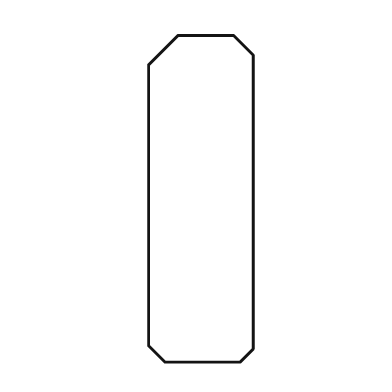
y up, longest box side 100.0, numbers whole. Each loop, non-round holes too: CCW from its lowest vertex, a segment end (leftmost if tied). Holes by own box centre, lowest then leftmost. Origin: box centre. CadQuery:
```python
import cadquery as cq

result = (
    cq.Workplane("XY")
    .moveTo(-11.0, -50.0)
    .lineTo(12.0, -50.0)
    .lineTo(16.0, -46.0)
    .lineTo(16.0, 44.0)
    .lineTo(10.0, 50.0)
    .lineTo(-7.0, 50.0)
    .lineTo(-16.0, 41.0)
    .lineTo(-16.0, -45.0)
    .close()
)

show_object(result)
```